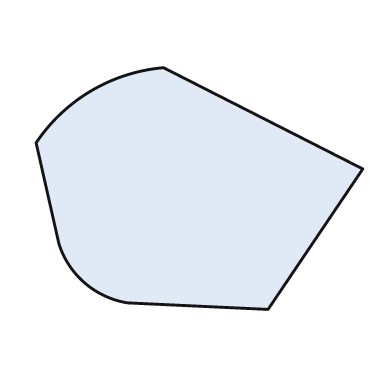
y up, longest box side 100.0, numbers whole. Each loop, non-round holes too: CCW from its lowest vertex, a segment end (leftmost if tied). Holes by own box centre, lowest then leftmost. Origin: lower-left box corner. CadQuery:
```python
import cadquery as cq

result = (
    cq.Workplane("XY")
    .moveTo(71.0, 0.0)
    .lineTo(100.0, 43.0)
    .lineTo(39.0, 74.0)
    .threePointArc((17.0, 67.0), (0.0, 51.0))
    .lineTo(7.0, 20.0)
    .threePointArc((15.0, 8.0), (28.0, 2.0))
    .close()
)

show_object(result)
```